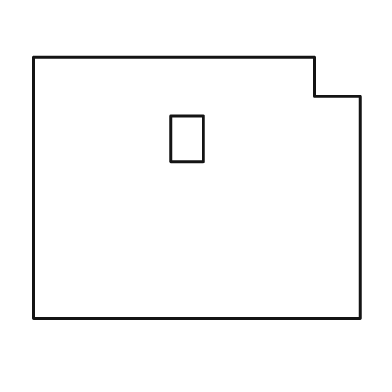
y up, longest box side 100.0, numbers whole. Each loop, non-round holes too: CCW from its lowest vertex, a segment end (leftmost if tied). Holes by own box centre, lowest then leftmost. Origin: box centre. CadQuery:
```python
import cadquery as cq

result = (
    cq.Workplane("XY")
    .moveTo(-50.0, -40.0)
    .lineTo(50.0, -40.0)
    .lineTo(50.0, 28.0)
    .lineTo(36.0, 28.0)
    .lineTo(36.0, 40.0)
    .lineTo(-50.0, 40.0)
    .close()
    .moveTo(-8.0, 8.0)
    .lineTo(2.0, 8.0)
    .lineTo(2.0, 22.0)
    .lineTo(-8.0, 22.0)
    .close()
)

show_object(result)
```